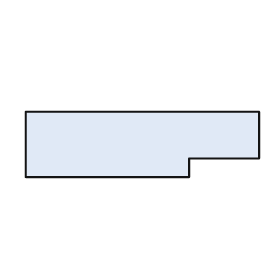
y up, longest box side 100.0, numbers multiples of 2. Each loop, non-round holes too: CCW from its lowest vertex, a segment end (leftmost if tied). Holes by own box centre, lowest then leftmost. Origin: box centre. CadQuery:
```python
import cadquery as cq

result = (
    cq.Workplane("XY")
    .moveTo(-50.0, -14.0)
    .lineTo(20.0, -14.0)
    .lineTo(20.0, -6.0)
    .lineTo(50.0, -6.0)
    .lineTo(50.0, 14.0)
    .lineTo(-50.0, 14.0)
    .close()
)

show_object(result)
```